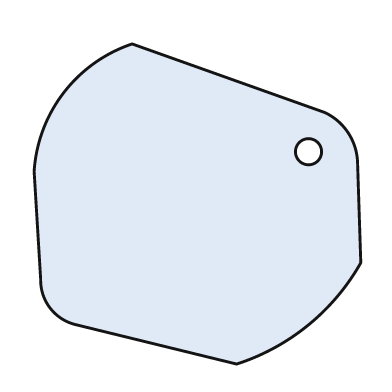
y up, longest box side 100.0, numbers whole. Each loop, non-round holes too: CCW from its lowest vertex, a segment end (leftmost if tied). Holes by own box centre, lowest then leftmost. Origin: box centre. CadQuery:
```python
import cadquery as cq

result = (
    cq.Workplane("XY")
    .moveTo(12.0, -49.0)
    .threePointArc((34.0, -37.0), (50.0, -18.0))
    .lineTo(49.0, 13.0)
    .threePointArc((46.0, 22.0), (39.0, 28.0))
    .lineTo(-20.0, 49.0)
    .threePointArc((-41.0, 34.0), (-50.0, 10.0))
    .lineTo(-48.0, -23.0)
    .threePointArc((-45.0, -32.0), (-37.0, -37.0))
    .close()
    .moveTo(34.0, 16.0)
    .circle(4.0)
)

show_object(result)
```